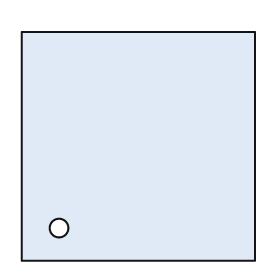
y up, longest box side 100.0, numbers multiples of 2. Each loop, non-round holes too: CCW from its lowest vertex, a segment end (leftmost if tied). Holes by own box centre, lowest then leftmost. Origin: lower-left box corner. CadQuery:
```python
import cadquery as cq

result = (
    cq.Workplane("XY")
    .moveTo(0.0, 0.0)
    .lineTo(100.0, 0.0)
    .lineTo(100.0, 98.0)
    .lineTo(0.0, 98.0)
    .close()
    .moveTo(16.0, 14.0)
    .circle(4.0)
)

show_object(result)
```